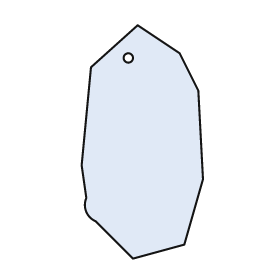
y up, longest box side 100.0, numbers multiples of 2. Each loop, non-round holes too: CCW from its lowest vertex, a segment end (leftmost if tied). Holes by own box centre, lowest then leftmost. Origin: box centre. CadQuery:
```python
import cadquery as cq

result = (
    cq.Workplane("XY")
    .moveTo(-4.0, -50.0)
    .lineTo(18.0, -44.0)
    .lineTo(26.0, -16.0)
    .lineTo(24.0, 22.0)
    .lineTo(16.0, 38.0)
    .lineTo(-2.0, 50.0)
    .lineTo(-22.0, 32.0)
    .lineTo(-26.0, -10.0)
    .lineTo(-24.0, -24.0)
    .threePointArc((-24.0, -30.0), (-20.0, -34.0))
    .close()
    .moveTo(-6.0, 36.0)
    .circle(2.0)
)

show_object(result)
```